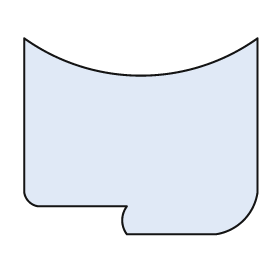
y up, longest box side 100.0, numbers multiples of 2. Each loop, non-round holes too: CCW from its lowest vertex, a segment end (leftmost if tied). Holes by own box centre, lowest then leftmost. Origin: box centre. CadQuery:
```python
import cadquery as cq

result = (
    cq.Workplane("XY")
    .moveTo(-6.0, -42.0)
    .lineTo(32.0, -42.0)
    .threePointArc((44.0, -36.0), (50.0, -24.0))
    .lineTo(50.0, 42.0)
    .threePointArc((0.0, 26.0), (-50.0, 42.0))
    .lineTo(-50.0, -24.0)
    .threePointArc((-48.0, -28.0), (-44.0, -30.0))
    .lineTo(-6.0, -30.0)
    .threePointArc((-8.0, -36.0), (-6.0, -42.0))
    .close()
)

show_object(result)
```